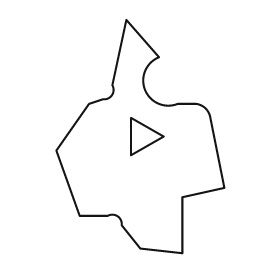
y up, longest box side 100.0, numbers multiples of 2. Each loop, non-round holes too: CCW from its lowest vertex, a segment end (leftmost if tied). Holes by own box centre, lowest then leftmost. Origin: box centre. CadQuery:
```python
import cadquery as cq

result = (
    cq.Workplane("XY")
    .moveTo(18.0, -50.0)
    .lineTo(18.0, -26.0)
    .lineTo(36.0, -22.0)
    .lineTo(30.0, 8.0)
    .threePointArc((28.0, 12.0), (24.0, 14.0))
    .lineTo(16.0, 14.0)
    .threePointArc((2.0, 20.0), (8.0, 34.0))
    .lineTo(-6.0, 50.0)
    .lineTo(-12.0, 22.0)
    .threePointArc((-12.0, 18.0), (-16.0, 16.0))
    .lineTo(-22.0, 14.0)
    .lineTo(-36.0, -6.0)
    .lineTo(-26.0, -34.0)
    .lineTo(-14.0, -34.0)
    .threePointArc((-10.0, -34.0), (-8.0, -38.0))
    .lineTo(0.0, -48.0)
    .close()
    .moveTo(-4.0, -8.0)
    .lineTo(10.0, 0.0)
    .lineTo(-4.0, 8.0)
    .close()
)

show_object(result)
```